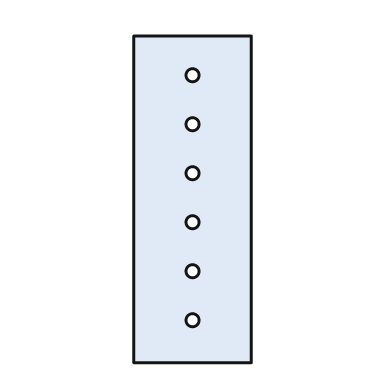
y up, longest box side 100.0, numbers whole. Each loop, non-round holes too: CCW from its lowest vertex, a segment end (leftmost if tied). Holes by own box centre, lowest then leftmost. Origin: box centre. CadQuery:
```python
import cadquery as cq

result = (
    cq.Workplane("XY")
    .moveTo(-18.0, -50.0)
    .lineTo(18.0, -50.0)
    .lineTo(18.0, 50.0)
    .lineTo(-18.0, 50.0)
    .close()
    .moveTo(0.0, -37.0)
    .circle(2.0)
    .moveTo(0.0, -22.0)
    .circle(2.0)
    .moveTo(0.0, -7.0)
    .circle(2.0)
    .moveTo(0.0, 8.0)
    .circle(2.0)
    .moveTo(0.0, 23.0)
    .circle(2.0)
    .moveTo(0.0, 38.0)
    .circle(2.0)
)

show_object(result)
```